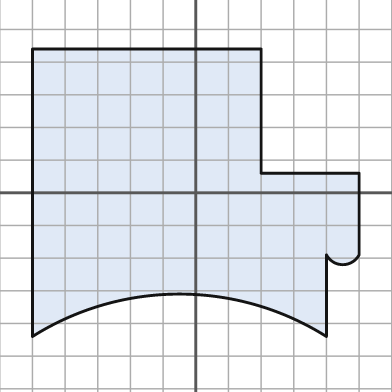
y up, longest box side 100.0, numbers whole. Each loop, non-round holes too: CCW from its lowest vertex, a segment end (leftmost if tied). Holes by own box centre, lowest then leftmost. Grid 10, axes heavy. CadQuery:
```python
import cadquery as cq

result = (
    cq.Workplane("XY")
    .moveTo(-50.0, -44.0)
    .threePointArc((-5.0, -31.0), (40.0, -44.0))
    .lineTo(40.0, -19.0)
    .threePointArc((45.0, -22.0), (50.0, -19.0))
    .lineTo(50.0, 6.0)
    .lineTo(20.0, 6.0)
    .lineTo(20.0, 44.0)
    .lineTo(-50.0, 44.0)
    .close()
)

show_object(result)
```